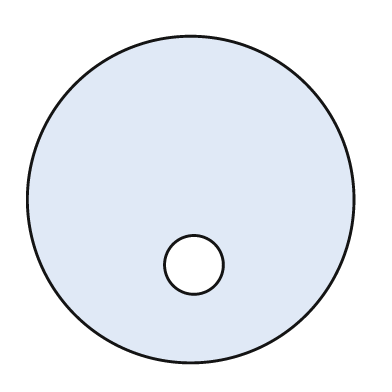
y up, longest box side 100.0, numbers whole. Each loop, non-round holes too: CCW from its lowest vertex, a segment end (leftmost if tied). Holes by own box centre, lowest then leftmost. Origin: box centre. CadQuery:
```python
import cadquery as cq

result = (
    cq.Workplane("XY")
    .moveTo(0.0, 0.0)
    .circle(50.0)
    .moveTo(1.0, -20.0)
    .circle(9.0)
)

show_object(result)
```